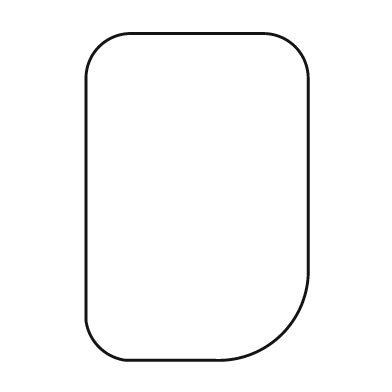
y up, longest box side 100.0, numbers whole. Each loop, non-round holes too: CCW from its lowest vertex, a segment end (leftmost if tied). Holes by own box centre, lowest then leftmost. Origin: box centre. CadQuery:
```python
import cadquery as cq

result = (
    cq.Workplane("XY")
    .moveTo(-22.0, -50.0)
    .lineTo(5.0, -50.0)
    .threePointArc((26.0, -42.0), (34.0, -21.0))
    .lineTo(34.0, 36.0)
    .threePointArc((30.0, 46.0), (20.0, 50.0))
    .lineTo(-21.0, 50.0)
    .threePointArc((-30.0, 46.0), (-34.0, 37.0))
    .lineTo(-34.0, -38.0)
    .threePointArc((-30.0, -46.0), (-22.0, -50.0))
    .close()
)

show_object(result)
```